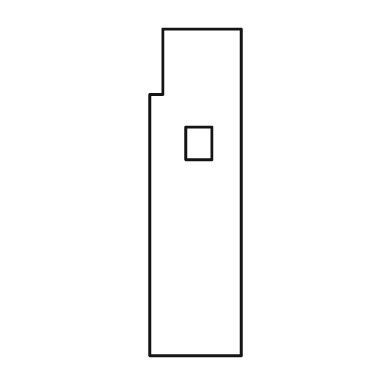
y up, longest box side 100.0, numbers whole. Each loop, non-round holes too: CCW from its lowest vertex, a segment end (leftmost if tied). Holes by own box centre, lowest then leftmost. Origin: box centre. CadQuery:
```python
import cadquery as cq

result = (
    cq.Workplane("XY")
    .moveTo(-14.0, -50.0)
    .lineTo(14.0, -50.0)
    .lineTo(14.0, 50.0)
    .lineTo(-10.0, 50.0)
    .lineTo(-10.0, 30.0)
    .lineTo(-14.0, 30.0)
    .close()
    .moveTo(-3.0, 10.0)
    .lineTo(5.0, 10.0)
    .lineTo(5.0, 20.0)
    .lineTo(-3.0, 20.0)
    .close()
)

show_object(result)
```